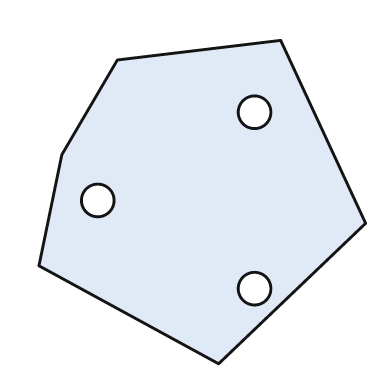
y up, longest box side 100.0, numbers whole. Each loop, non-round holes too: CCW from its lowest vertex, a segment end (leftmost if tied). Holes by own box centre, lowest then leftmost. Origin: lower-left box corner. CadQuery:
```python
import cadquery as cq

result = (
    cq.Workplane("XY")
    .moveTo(55.0, 0.0)
    .lineTo(100.0, 43.0)
    .lineTo(74.0, 99.0)
    .lineTo(24.0, 93.0)
    .lineTo(7.0, 64.0)
    .lineTo(0.0, 30.0)
    .close()
    .moveTo(66.0, 23.0)
    .circle(5.0)
    .moveTo(18.0, 50.0)
    .circle(5.0)
    .moveTo(66.0, 77.0)
    .circle(5.0)
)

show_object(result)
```